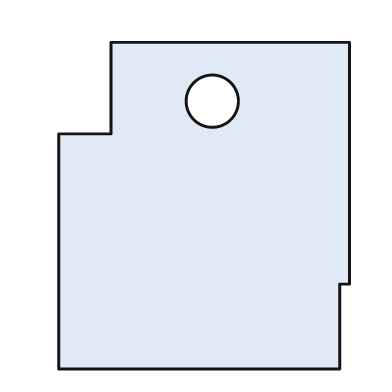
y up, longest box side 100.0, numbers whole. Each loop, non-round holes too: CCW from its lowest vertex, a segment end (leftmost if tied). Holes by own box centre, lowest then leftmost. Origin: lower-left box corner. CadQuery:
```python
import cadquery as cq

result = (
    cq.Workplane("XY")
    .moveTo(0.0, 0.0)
    .lineTo(86.0, 0.0)
    .lineTo(86.0, 26.0)
    .lineTo(89.0, 26.0)
    .lineTo(89.0, 100.0)
    .lineTo(16.0, 100.0)
    .lineTo(16.0, 72.0)
    .lineTo(0.0, 72.0)
    .close()
    .moveTo(47.0, 82.0)
    .circle(8.0)
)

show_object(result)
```